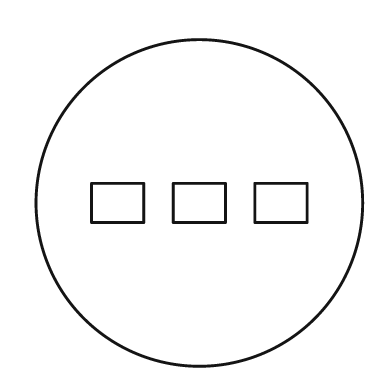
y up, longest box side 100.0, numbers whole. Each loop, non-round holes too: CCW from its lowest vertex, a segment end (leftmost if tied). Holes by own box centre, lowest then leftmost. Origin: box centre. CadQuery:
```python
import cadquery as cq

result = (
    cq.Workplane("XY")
    .moveTo(0.0, 0.0)
    .circle(50.0)
    .moveTo(-33.0, -6.0)
    .lineTo(-17.0, -6.0)
    .lineTo(-17.0, 6.0)
    .lineTo(-33.0, 6.0)
    .close()
    .moveTo(-8.0, -6.0)
    .lineTo(8.0, -6.0)
    .lineTo(8.0, 6.0)
    .lineTo(-8.0, 6.0)
    .close()
    .moveTo(17.0, -6.0)
    .lineTo(33.0, -6.0)
    .lineTo(33.0, 6.0)
    .lineTo(17.0, 6.0)
    .close()
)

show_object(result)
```